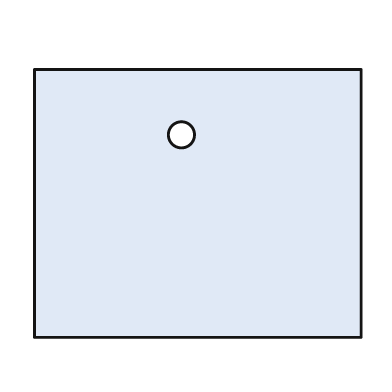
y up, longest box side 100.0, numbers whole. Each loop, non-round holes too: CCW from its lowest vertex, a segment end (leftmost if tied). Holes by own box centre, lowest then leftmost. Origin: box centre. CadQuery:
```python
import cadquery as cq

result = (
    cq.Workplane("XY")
    .moveTo(-50.0, -41.0)
    .lineTo(50.0, -41.0)
    .lineTo(50.0, 41.0)
    .lineTo(-50.0, 41.0)
    .close()
    .moveTo(-5.0, 21.0)
    .circle(4.0)
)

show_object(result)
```